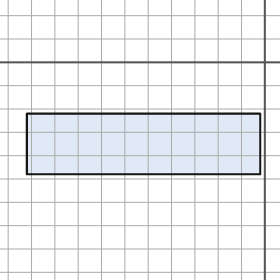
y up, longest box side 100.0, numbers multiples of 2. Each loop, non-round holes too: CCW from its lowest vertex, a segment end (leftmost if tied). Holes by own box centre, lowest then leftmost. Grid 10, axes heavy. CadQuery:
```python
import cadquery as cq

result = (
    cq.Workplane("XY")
    .moveTo(-102.0, -48.0)
    .lineTo(-2.0, -48.0)
    .lineTo(-2.0, -22.0)
    .lineTo(-102.0, -22.0)
    .close()
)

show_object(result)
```